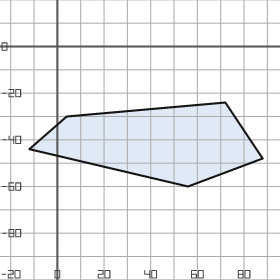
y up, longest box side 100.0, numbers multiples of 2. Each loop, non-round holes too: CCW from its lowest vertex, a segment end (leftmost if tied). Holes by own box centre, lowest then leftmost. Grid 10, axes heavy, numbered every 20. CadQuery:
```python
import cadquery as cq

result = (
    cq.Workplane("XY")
    .moveTo(56.0, -60.0)
    .lineTo(88.0, -48.0)
    .lineTo(72.0, -24.0)
    .lineTo(4.0, -30.0)
    .lineTo(-12.0, -44.0)
    .close()
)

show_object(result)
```